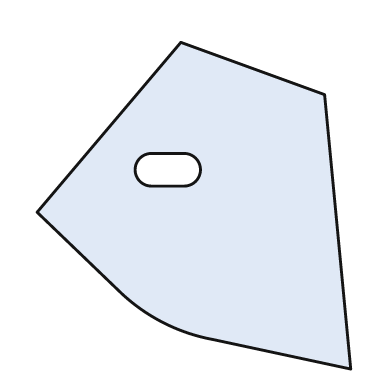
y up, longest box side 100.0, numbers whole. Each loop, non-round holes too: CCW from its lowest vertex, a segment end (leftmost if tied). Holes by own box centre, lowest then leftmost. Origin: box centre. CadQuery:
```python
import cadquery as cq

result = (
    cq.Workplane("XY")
    .moveTo(48.0, -50.0)
    .lineTo(40.0, 34.0)
    .lineTo(-4.0, 50.0)
    .lineTo(-48.0, -2.0)
    .lineTo(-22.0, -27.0)
    .threePointArc((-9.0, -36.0), (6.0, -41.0))
    .close()
    .moveTo(-13.0, 6.0)
    .lineTo(-3.0, 6.0)
    .threePointArc((2.0, 11.0), (-3.0, 16.0))
    .lineTo(-13.0, 16.0)
    .threePointArc((-18.0, 11.0), (-13.0, 6.0))
    .close()
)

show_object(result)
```